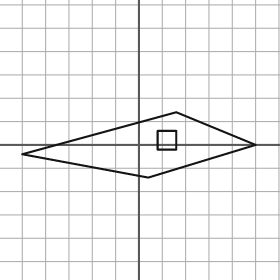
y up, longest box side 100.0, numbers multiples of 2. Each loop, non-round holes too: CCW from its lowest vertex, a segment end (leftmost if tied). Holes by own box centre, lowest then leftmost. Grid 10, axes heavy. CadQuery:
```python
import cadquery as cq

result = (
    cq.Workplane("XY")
    .moveTo(4.0, -14.0)
    .lineTo(50.0, 0.0)
    .lineTo(16.0, 14.0)
    .lineTo(-50.0, -4.0)
    .close()
    .moveTo(8.0, -2.0)
    .lineTo(16.0, -2.0)
    .lineTo(16.0, 6.0)
    .lineTo(8.0, 6.0)
    .close()
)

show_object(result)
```